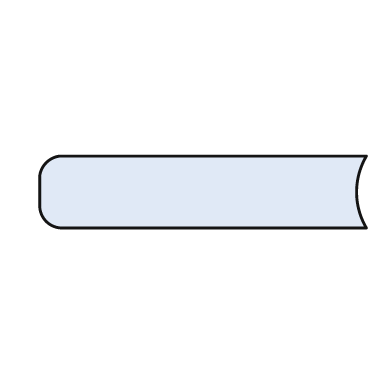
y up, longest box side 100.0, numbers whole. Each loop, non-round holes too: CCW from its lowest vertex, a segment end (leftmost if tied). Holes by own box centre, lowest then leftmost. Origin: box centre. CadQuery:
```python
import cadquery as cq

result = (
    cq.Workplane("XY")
    .moveTo(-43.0, -11.0)
    .lineTo(50.0, -11.0)
    .threePointArc((47.0, 0.0), (50.0, 11.0))
    .lineTo(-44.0, 11.0)
    .threePointArc((-48.0, 9.0), (-50.0, 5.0))
    .lineTo(-50.0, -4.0)
    .threePointArc((-48.0, -9.0), (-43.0, -11.0))
    .close()
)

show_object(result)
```